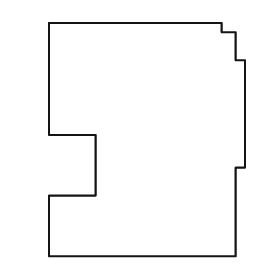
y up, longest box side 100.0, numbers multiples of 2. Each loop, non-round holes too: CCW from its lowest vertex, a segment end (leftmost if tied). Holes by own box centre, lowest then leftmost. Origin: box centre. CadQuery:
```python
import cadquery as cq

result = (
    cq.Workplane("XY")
    .moveTo(-42.0, -50.0)
    .lineTo(38.0, -50.0)
    .lineTo(38.0, -12.0)
    .lineTo(42.0, -12.0)
    .lineTo(42.0, 34.0)
    .lineTo(38.0, 34.0)
    .lineTo(38.0, 46.0)
    .lineTo(32.0, 46.0)
    .lineTo(32.0, 50.0)
    .lineTo(-42.0, 50.0)
    .lineTo(-42.0, 2.0)
    .lineTo(-22.0, 2.0)
    .lineTo(-22.0, -24.0)
    .lineTo(-42.0, -24.0)
    .close()
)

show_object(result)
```